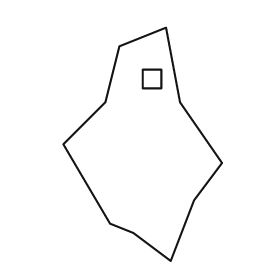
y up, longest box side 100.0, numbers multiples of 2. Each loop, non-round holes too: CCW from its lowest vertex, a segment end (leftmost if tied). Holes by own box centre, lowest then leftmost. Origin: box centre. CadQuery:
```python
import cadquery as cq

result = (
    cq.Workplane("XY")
    .moveTo(12.0, -50.0)
    .lineTo(22.0, -24.0)
    .lineTo(34.0, -8.0)
    .lineTo(16.0, 18.0)
    .lineTo(10.0, 50.0)
    .lineTo(-10.0, 42.0)
    .lineTo(-16.0, 18.0)
    .lineTo(-34.0, 0.0)
    .lineTo(-14.0, -34.0)
    .lineTo(-4.0, -38.0)
    .close()
    .moveTo(0.0, 24.0)
    .lineTo(8.0, 24.0)
    .lineTo(8.0, 32.0)
    .lineTo(0.0, 32.0)
    .close()
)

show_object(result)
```